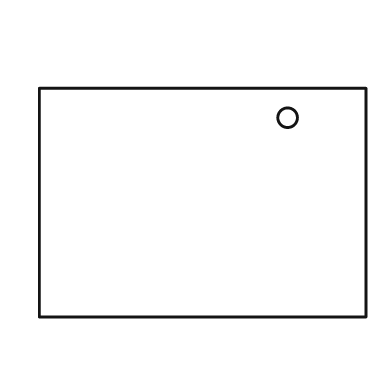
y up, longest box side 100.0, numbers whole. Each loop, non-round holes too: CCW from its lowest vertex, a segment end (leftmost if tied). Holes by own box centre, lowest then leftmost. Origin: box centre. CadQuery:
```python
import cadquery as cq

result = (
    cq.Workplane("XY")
    .moveTo(-50.0, -35.0)
    .lineTo(50.0, -35.0)
    .lineTo(50.0, 35.0)
    .lineTo(-50.0, 35.0)
    .close()
    .moveTo(26.0, 26.0)
    .circle(3.0)
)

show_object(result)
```